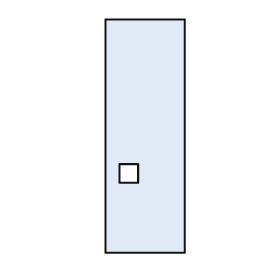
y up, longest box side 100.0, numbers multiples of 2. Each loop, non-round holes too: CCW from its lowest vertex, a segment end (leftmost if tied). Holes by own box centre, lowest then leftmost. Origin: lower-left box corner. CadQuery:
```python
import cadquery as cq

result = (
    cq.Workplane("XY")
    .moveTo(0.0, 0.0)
    .lineTo(34.0, 0.0)
    .lineTo(34.0, 100.0)
    .lineTo(0.0, 100.0)
    .close()
    .moveTo(6.0, 30.0)
    .lineTo(14.0, 30.0)
    .lineTo(14.0, 38.0)
    .lineTo(6.0, 38.0)
    .close()
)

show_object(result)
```